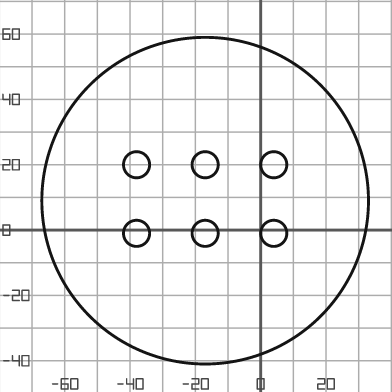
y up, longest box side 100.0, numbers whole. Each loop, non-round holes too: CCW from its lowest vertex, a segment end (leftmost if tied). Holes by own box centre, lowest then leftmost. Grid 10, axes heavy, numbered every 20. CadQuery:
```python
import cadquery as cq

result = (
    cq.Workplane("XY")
    .moveTo(-17.0, 9.0)
    .circle(50.0)
    .moveTo(-38.0, -1.0)
    .circle(4.0)
    .moveTo(-17.0, -1.0)
    .circle(4.0)
    .moveTo(4.0, -1.0)
    .circle(4.0)
    .moveTo(-38.0, 20.0)
    .circle(4.0)
    .moveTo(-17.0, 20.0)
    .circle(4.0)
    .moveTo(4.0, 20.0)
    .circle(4.0)
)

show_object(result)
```